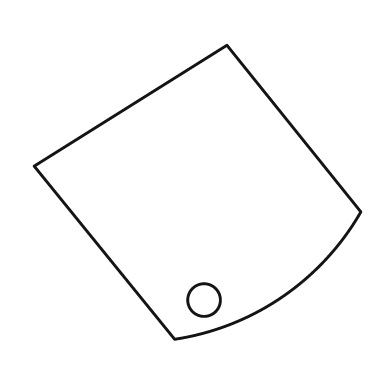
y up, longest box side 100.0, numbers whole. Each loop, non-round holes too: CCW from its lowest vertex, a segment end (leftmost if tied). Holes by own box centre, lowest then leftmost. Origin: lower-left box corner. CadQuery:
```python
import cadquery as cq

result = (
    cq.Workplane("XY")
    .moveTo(43.0, 0.0)
    .threePointArc((76.0, 13.0), (100.0, 39.0))
    .lineTo(59.0, 90.0)
    .lineTo(0.0, 53.0)
    .close()
    .moveTo(52.0, 12.0)
    .circle(5.0)
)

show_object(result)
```